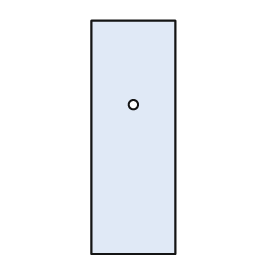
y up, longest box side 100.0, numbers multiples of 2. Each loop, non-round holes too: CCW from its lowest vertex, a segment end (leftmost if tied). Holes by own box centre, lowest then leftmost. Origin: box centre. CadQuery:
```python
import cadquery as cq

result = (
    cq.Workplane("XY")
    .moveTo(-18.0, -50.0)
    .lineTo(18.0, -50.0)
    .lineTo(18.0, 50.0)
    .lineTo(-18.0, 50.0)
    .close()
    .moveTo(0.0, 14.0)
    .circle(2.0)
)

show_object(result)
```